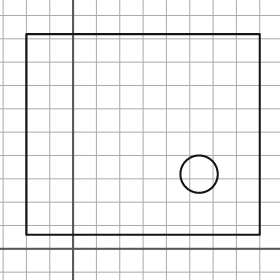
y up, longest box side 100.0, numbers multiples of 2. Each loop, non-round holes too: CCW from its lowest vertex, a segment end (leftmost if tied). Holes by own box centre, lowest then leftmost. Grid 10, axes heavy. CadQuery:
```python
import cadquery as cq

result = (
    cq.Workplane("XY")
    .moveTo(-20.0, 6.0)
    .lineTo(80.0, 6.0)
    .lineTo(80.0, 92.0)
    .lineTo(-20.0, 92.0)
    .close()
    .moveTo(54.0, 32.0)
    .circle(8.0)
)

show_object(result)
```